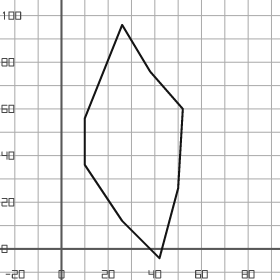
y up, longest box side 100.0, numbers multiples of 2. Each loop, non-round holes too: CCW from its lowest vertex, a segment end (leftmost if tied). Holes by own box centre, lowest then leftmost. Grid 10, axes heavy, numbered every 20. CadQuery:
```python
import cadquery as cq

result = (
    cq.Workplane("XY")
    .moveTo(42.0, -4.0)
    .lineTo(50.0, 26.0)
    .lineTo(52.0, 60.0)
    .lineTo(38.0, 76.0)
    .lineTo(26.0, 96.0)
    .lineTo(10.0, 56.0)
    .lineTo(10.0, 36.0)
    .lineTo(26.0, 12.0)
    .close()
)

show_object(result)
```